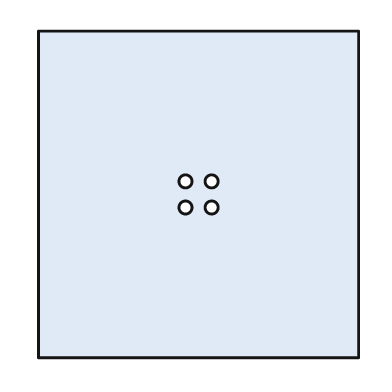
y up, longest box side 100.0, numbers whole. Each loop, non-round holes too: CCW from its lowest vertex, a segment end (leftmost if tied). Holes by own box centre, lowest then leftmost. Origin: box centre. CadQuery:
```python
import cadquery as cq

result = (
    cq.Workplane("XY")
    .moveTo(-49.0, -50.0)
    .lineTo(49.0, -50.0)
    .lineTo(49.0, 50.0)
    .lineTo(-49.0, 50.0)
    .close()
    .moveTo(-4.0, -4.0)
    .circle(2.0)
    .moveTo(4.0, -4.0)
    .circle(2.0)
    .moveTo(-4.0, 4.0)
    .circle(2.0)
    .moveTo(4.0, 4.0)
    .circle(2.0)
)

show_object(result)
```